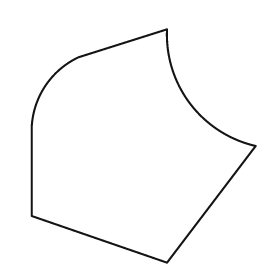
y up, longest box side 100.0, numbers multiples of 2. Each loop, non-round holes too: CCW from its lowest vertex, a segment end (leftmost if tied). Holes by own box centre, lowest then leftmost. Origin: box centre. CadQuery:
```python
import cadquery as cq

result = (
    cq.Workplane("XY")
    .moveTo(10.0, -50.0)
    .lineTo(48.0, 0.0)
    .threePointArc((20.0, 18.0), (10.0, 50.0))
    .lineTo(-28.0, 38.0)
    .threePointArc((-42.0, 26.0), (-48.0, 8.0))
    .lineTo(-48.0, -30.0)
    .close()
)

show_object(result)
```